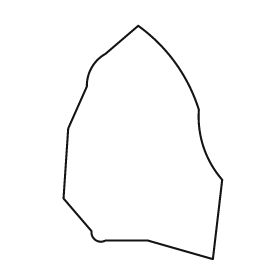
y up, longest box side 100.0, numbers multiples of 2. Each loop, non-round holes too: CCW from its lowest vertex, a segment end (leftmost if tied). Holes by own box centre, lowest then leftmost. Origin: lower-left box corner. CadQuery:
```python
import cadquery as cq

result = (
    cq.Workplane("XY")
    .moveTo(64.0, 0.0)
    .lineTo(68.0, 34.0)
    .threePointArc((60.0, 48.0), (58.0, 64.0))
    .threePointArc((48.0, 84.0), (32.0, 100.0))
    .lineTo(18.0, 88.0)
    .threePointArc((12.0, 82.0), (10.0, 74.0))
    .lineTo(2.0, 56.0)
    .lineTo(0.0, 26.0)
    .lineTo(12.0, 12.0)
    .threePointArc((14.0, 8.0), (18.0, 8.0))
    .lineTo(36.0, 8.0)
    .close()
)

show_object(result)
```